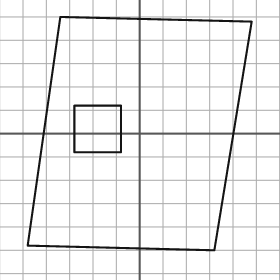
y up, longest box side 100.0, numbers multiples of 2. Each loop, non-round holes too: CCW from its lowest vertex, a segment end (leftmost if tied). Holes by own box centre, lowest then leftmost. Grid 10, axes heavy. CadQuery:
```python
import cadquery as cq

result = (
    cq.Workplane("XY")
    .moveTo(32.0, -50.0)
    .lineTo(48.0, 48.0)
    .lineTo(-34.0, 50.0)
    .lineTo(-48.0, -48.0)
    .close()
    .moveTo(-28.0, -8.0)
    .lineTo(-8.0, -8.0)
    .lineTo(-8.0, 12.0)
    .lineTo(-28.0, 12.0)
    .close()
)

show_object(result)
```